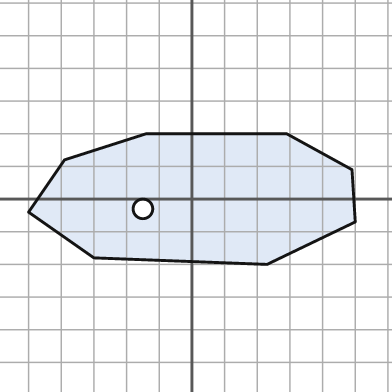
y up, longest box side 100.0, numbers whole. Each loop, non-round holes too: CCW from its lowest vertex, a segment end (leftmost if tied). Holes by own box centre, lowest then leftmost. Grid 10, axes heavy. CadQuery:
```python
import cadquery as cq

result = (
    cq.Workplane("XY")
    .moveTo(23.0, -20.0)
    .lineTo(50.0, -7.0)
    .lineTo(49.0, 9.0)
    .lineTo(29.0, 20.0)
    .lineTo(-14.0, 20.0)
    .lineTo(-39.0, 12.0)
    .lineTo(-50.0, -4.0)
    .lineTo(-30.0, -18.0)
    .close()
    .moveTo(-15.0, -3.0)
    .circle(3.0)
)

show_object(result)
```